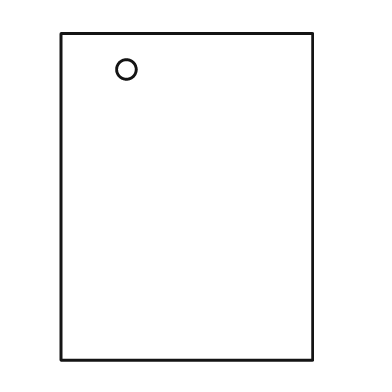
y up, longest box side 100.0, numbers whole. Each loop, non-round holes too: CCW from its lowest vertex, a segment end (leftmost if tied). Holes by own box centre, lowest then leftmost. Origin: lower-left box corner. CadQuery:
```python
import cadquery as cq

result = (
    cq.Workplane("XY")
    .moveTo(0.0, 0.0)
    .lineTo(77.0, 0.0)
    .lineTo(77.0, 100.0)
    .lineTo(0.0, 100.0)
    .close()
    .moveTo(20.0, 89.0)
    .circle(3.0)
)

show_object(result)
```